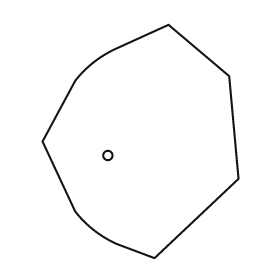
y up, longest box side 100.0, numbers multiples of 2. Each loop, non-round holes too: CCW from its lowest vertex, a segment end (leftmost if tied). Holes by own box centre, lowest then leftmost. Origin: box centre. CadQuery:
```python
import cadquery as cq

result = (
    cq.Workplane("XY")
    .moveTo(6.0, -50.0)
    .lineTo(42.0, -16.0)
    .lineTo(38.0, 28.0)
    .lineTo(12.0, 50.0)
    .lineTo(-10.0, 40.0)
    .threePointArc((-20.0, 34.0), (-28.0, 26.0))
    .lineTo(-42.0, 0.0)
    .lineTo(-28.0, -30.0)
    .threePointArc((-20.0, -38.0), (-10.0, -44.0))
    .close()
    .moveTo(-14.0, -6.0)
    .circle(2.0)
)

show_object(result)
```